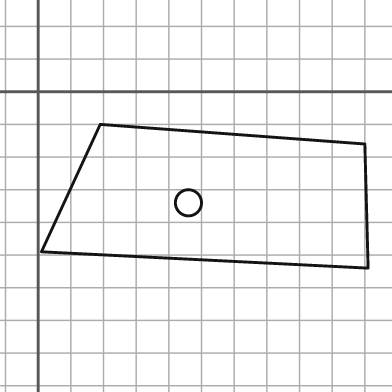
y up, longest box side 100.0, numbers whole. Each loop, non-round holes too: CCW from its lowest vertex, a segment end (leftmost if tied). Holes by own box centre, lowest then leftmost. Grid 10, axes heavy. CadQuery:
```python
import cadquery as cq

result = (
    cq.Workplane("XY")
    .moveTo(101.0, -54.0)
    .lineTo(100.0, -16.0)
    .lineTo(19.0, -10.0)
    .lineTo(1.0, -49.0)
    .close()
    .moveTo(46.0, -34.0)
    .circle(4.0)
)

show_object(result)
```